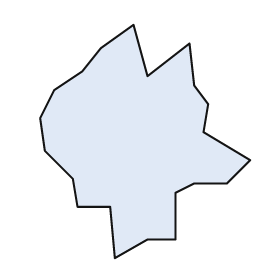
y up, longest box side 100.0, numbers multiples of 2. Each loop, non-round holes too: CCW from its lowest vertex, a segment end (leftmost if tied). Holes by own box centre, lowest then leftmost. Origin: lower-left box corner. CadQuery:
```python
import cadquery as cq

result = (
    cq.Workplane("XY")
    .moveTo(32.0, 0.0)
    .lineTo(46.0, 8.0)
    .lineTo(58.0, 8.0)
    .lineTo(58.0, 28.0)
    .lineTo(66.0, 32.0)
    .lineTo(80.0, 32.0)
    .lineTo(90.0, 42.0)
    .lineTo(70.0, 54.0)
    .lineTo(72.0, 66.0)
    .lineTo(66.0, 74.0)
    .lineTo(64.0, 92.0)
    .lineTo(46.0, 78.0)
    .lineTo(40.0, 100.0)
    .lineTo(26.0, 90.0)
    .lineTo(18.0, 80.0)
    .lineTo(6.0, 72.0)
    .lineTo(0.0, 60.0)
    .lineTo(2.0, 46.0)
    .lineTo(14.0, 34.0)
    .lineTo(16.0, 22.0)
    .lineTo(30.0, 22.0)
    .close()
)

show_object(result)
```